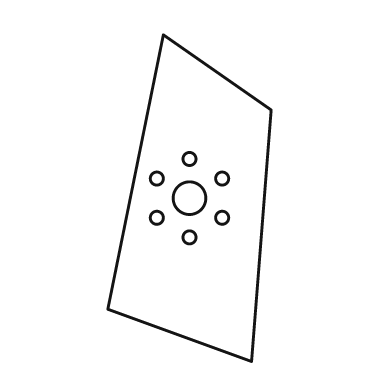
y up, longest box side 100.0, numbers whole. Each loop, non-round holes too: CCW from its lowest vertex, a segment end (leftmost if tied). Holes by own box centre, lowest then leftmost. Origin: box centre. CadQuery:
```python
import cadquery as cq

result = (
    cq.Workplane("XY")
    .moveTo(19.0, -50.0)
    .lineTo(25.0, 27.0)
    .lineTo(-8.0, 50.0)
    .lineTo(-25.0, -34.0)
    .close()
    .moveTo(0.0, -12.0)
    .circle(2.0)
    .moveTo(-10.0, -6.0)
    .circle(2.0)
    .moveTo(10.0, -6.0)
    .circle(2.0)
    .moveTo(0.0, 0.0)
    .circle(5.0)
    .moveTo(-10.0, 6.0)
    .circle(2.0)
    .moveTo(10.0, 6.0)
    .circle(2.0)
    .moveTo(0.0, 12.0)
    .circle(2.0)
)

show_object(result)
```